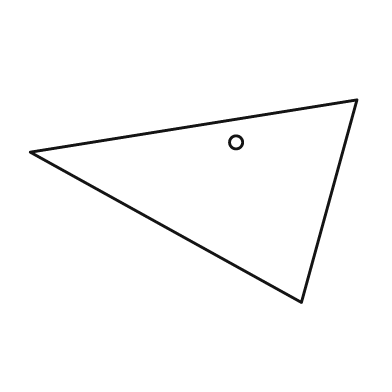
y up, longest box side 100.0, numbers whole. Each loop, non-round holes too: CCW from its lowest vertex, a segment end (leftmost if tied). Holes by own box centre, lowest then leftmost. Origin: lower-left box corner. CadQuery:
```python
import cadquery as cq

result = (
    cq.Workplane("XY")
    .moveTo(83.0, 0.0)
    .lineTo(100.0, 62.0)
    .lineTo(0.0, 46.0)
    .close()
    .moveTo(63.0, 49.0)
    .circle(2.0)
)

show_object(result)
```